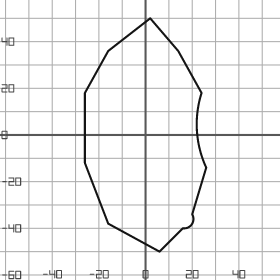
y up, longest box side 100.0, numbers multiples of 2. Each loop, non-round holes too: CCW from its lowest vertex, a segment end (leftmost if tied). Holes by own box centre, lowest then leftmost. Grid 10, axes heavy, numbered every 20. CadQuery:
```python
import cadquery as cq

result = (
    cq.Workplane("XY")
    .moveTo(6.0, -50.0)
    .lineTo(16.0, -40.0)
    .threePointArc((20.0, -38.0), (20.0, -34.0))
    .lineTo(26.0, -14.0)
    .threePointArc((22.0, 2.0), (24.0, 18.0))
    .lineTo(14.0, 36.0)
    .lineTo(2.0, 50.0)
    .lineTo(-16.0, 36.0)
    .lineTo(-26.0, 18.0)
    .lineTo(-26.0, -12.0)
    .lineTo(-16.0, -38.0)
    .close()
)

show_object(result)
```